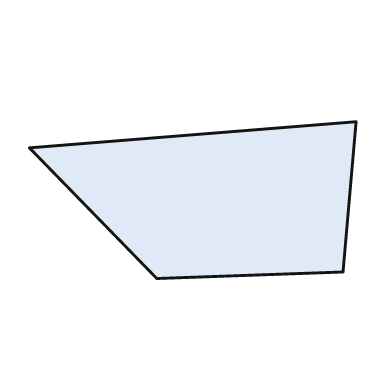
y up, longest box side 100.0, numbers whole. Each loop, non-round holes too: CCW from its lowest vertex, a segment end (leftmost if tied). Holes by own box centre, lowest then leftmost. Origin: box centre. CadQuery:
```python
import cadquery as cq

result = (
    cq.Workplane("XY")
    .moveTo(-11.0, -24.0)
    .lineTo(46.0, -22.0)
    .lineTo(50.0, 24.0)
    .lineTo(-50.0, 16.0)
    .close()
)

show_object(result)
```